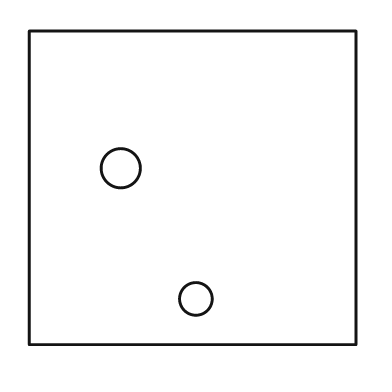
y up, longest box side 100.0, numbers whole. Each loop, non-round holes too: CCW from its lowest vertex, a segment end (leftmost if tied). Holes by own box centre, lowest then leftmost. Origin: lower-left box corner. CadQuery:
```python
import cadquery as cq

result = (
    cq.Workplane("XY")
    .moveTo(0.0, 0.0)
    .lineTo(100.0, 0.0)
    .lineTo(100.0, 96.0)
    .lineTo(0.0, 96.0)
    .close()
    .moveTo(51.0, 14.0)
    .circle(5.0)
    .moveTo(28.0, 54.0)
    .circle(6.0)
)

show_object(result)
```